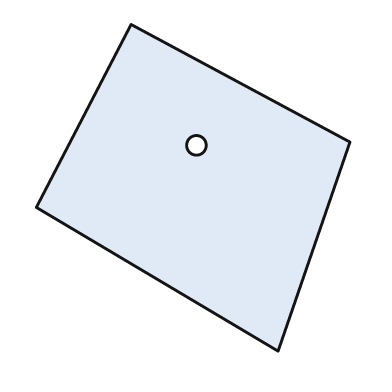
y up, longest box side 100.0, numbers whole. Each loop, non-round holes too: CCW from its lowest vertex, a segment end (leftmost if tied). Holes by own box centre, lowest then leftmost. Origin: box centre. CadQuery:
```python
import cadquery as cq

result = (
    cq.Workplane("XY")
    .moveTo(26.0, -50.0)
    .lineTo(48.0, 14.0)
    .lineTo(-19.0, 50.0)
    .lineTo(-48.0, -6.0)
    .close()
    .moveTo(1.0, 13.0)
    .circle(3.0)
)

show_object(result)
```